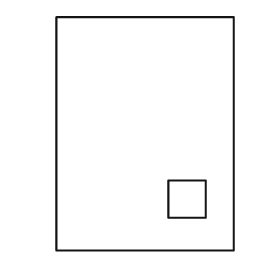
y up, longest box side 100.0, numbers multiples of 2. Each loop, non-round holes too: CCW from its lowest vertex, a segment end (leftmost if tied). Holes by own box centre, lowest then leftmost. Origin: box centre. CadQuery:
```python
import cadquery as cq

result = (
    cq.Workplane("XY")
    .moveTo(-38.0, -50.0)
    .lineTo(38.0, -50.0)
    .lineTo(38.0, 50.0)
    .lineTo(-38.0, 50.0)
    .close()
    .moveTo(10.0, -36.0)
    .lineTo(26.0, -36.0)
    .lineTo(26.0, -20.0)
    .lineTo(10.0, -20.0)
    .close()
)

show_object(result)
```